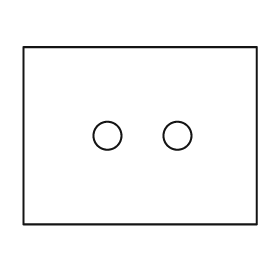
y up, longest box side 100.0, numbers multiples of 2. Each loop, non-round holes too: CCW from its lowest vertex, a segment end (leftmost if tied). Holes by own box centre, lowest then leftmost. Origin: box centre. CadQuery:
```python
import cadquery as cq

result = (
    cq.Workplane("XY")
    .moveTo(-50.0, -38.0)
    .lineTo(50.0, -38.0)
    .lineTo(50.0, 38.0)
    .lineTo(-50.0, 38.0)
    .close()
    .moveTo(-14.0, 0.0)
    .circle(6.0)
    .moveTo(16.0, 0.0)
    .circle(6.0)
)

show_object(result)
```